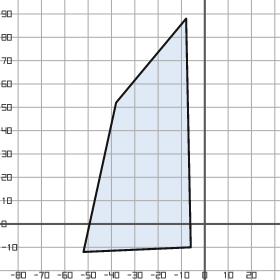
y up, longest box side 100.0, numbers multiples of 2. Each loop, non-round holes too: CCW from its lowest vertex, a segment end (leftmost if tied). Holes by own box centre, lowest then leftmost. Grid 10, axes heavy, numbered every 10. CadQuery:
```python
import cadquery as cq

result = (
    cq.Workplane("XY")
    .moveTo(-52.0, -12.0)
    .lineTo(-6.0, -10.0)
    .lineTo(-8.0, 88.0)
    .lineTo(-38.0, 52.0)
    .close()
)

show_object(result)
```